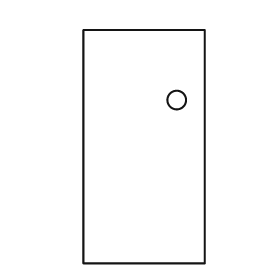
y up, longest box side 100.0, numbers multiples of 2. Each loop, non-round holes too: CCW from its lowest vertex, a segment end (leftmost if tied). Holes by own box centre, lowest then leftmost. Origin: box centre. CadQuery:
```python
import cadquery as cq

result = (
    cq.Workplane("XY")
    .moveTo(-26.0, -50.0)
    .lineTo(26.0, -50.0)
    .lineTo(26.0, 50.0)
    .lineTo(-26.0, 50.0)
    .close()
    .moveTo(14.0, 20.0)
    .circle(4.0)
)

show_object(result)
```